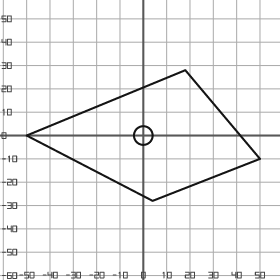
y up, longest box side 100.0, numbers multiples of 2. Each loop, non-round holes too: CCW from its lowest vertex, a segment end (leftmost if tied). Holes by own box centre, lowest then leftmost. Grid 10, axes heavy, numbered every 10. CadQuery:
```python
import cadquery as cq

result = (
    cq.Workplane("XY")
    .moveTo(4.0, -28.0)
    .lineTo(50.0, -10.0)
    .lineTo(18.0, 28.0)
    .lineTo(-50.0, 0.0)
    .close()
    .moveTo(0.0, 0.0)
    .circle(4.0)
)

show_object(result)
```